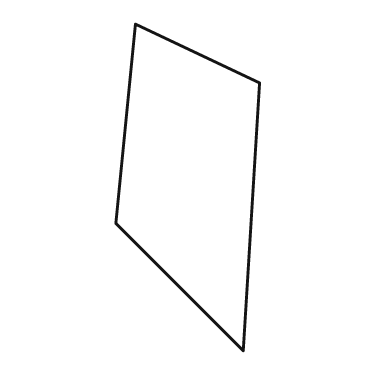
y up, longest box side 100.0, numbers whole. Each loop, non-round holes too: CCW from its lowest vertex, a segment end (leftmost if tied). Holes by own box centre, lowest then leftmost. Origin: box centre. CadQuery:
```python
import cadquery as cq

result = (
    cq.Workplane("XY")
    .moveTo(17.0, -50.0)
    .lineTo(22.0, 32.0)
    .lineTo(-16.0, 50.0)
    .lineTo(-22.0, -11.0)
    .close()
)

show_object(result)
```